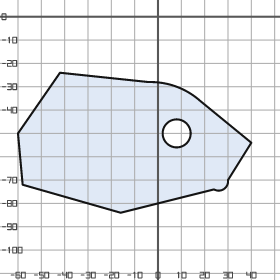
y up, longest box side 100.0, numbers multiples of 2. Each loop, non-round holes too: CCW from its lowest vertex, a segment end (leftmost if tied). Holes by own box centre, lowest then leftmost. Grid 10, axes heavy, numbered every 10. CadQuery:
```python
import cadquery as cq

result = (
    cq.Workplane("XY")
    .moveTo(-16.0, -84.0)
    .lineTo(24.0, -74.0)
    .threePointArc((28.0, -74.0), (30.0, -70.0))
    .lineTo(40.0, -54.0)
    .lineTo(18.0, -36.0)
    .threePointArc((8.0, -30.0), (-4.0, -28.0))
    .lineTo(-42.0, -24.0)
    .lineTo(-60.0, -50.0)
    .lineTo(-58.0, -72.0)
    .close()
    .moveTo(8.0, -50.0)
    .circle(6.0)
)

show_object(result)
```